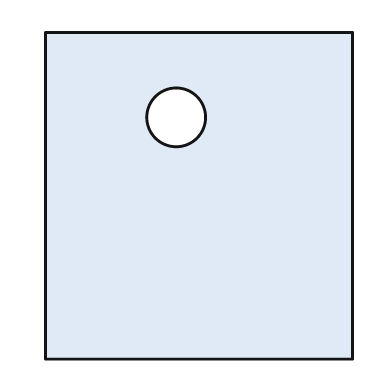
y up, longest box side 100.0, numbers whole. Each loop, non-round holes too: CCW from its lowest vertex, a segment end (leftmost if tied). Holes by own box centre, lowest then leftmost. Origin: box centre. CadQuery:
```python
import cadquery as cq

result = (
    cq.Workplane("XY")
    .moveTo(-47.0, -50.0)
    .lineTo(47.0, -50.0)
    .lineTo(47.0, 50.0)
    .lineTo(-47.0, 50.0)
    .close()
    .moveTo(-7.0, 24.0)
    .circle(9.0)
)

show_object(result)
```